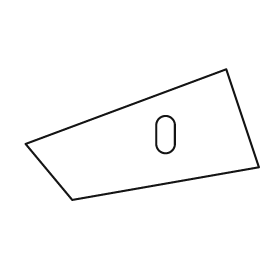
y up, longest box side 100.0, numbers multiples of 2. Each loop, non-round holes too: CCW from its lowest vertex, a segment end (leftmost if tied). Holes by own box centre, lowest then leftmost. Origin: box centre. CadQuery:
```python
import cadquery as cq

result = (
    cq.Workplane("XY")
    .moveTo(-30.0, -28.0)
    .lineTo(50.0, -14.0)
    .lineTo(36.0, 28.0)
    .lineTo(-50.0, -4.0)
    .close()
    .moveTo(6.0, -4.0)
    .threePointArc((10.0, -8.0), (14.0, -4.0))
    .lineTo(14.0, 4.0)
    .threePointArc((10.0, 8.0), (6.0, 4.0))
    .close()
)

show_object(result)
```